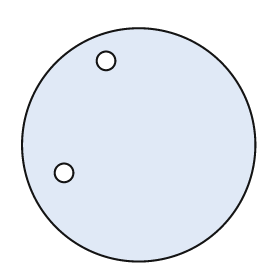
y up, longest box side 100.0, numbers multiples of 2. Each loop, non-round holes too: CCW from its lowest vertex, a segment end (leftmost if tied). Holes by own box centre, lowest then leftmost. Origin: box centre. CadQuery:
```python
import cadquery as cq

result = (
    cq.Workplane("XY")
    .moveTo(0.0, 0.0)
    .circle(50.0)
    .moveTo(-32.0, -12.0)
    .circle(4.0)
    .moveTo(-14.0, 36.0)
    .circle(4.0)
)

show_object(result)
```